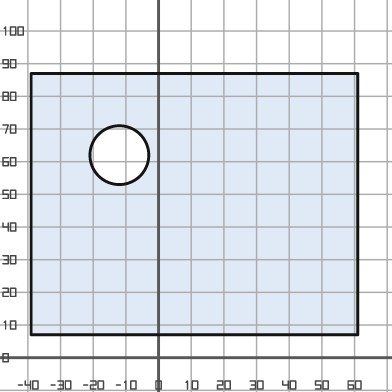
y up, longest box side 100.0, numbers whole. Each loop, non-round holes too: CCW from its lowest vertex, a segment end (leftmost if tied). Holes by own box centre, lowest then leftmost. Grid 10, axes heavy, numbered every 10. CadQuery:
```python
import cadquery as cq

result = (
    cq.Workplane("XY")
    .moveTo(-39.0, 7.0)
    .lineTo(61.0, 7.0)
    .lineTo(61.0, 87.0)
    .lineTo(-39.0, 87.0)
    .close()
    .moveTo(-12.0, 62.0)
    .circle(9.0)
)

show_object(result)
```